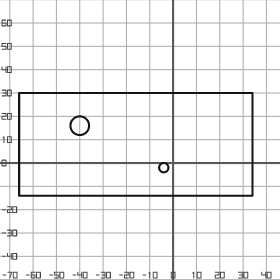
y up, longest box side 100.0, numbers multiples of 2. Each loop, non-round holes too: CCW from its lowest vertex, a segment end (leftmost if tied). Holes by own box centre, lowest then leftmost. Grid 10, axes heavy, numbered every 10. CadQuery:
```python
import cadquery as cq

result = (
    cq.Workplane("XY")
    .moveTo(-66.0, -14.0)
    .lineTo(34.0, -14.0)
    .lineTo(34.0, 30.0)
    .lineTo(-66.0, 30.0)
    .close()
    .moveTo(-4.0, -2.0)
    .circle(2.0)
    .moveTo(-40.0, 16.0)
    .circle(4.0)
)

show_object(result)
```